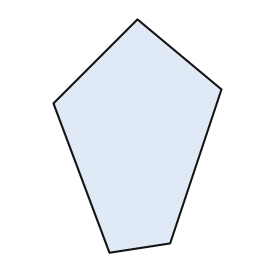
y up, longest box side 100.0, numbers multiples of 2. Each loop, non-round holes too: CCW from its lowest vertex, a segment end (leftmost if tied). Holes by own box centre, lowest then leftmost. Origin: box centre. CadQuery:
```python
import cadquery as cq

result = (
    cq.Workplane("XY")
    .moveTo(-12.0, -50.0)
    .lineTo(14.0, -46.0)
    .lineTo(36.0, 20.0)
    .lineTo(0.0, 50.0)
    .lineTo(-36.0, 14.0)
    .close()
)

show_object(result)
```